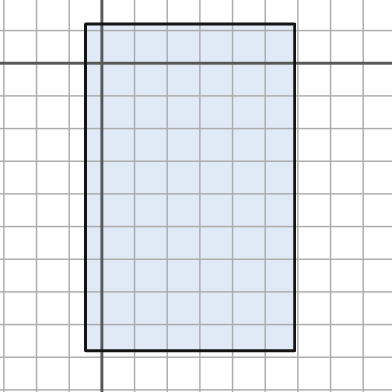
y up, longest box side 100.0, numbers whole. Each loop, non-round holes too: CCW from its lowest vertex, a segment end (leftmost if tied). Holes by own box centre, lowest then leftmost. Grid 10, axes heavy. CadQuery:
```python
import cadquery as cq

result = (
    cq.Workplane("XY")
    .moveTo(-5.0, -88.0)
    .lineTo(59.0, -88.0)
    .lineTo(59.0, 12.0)
    .lineTo(-5.0, 12.0)
    .close()
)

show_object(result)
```